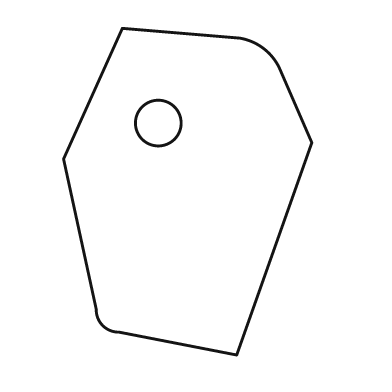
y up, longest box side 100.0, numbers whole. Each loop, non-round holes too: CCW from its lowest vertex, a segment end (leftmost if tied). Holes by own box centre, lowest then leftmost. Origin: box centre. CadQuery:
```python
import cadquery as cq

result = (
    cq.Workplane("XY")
    .moveTo(15.0, -50.0)
    .lineTo(38.0, 15.0)
    .lineTo(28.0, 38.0)
    .threePointArc((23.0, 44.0), (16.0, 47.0))
    .lineTo(-20.0, 50.0)
    .lineTo(-38.0, 10.0)
    .lineTo(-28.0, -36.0)
    .threePointArc((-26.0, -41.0), (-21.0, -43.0))
    .close()
    .moveTo(-9.0, 21.0)
    .circle(7.0)
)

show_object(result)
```